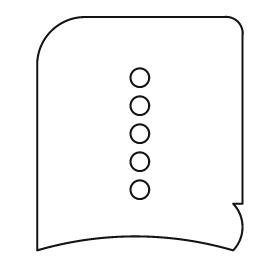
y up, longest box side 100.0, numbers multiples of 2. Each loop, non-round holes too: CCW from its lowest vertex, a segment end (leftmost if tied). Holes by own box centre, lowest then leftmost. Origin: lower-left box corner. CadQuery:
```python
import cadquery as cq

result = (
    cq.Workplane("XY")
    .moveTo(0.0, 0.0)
    .threePointArc((42.0, 6.0), (84.0, 0.0))
    .threePointArc((88.0, 10.0), (84.0, 20.0))
    .lineTo(88.0, 20.0)
    .lineTo(88.0, 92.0)
    .threePointArc((86.0, 98.0), (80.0, 100.0))
    .lineTo(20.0, 100.0)
    .threePointArc((6.0, 94.0), (0.0, 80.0))
    .close()
    .moveTo(44.0, 26.0)
    .circle(4.0)
    .moveTo(44.0, 38.0)
    .circle(4.0)
    .moveTo(44.0, 50.0)
    .circle(4.0)
    .moveTo(44.0, 62.0)
    .circle(4.0)
    .moveTo(44.0, 74.0)
    .circle(4.0)
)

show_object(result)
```